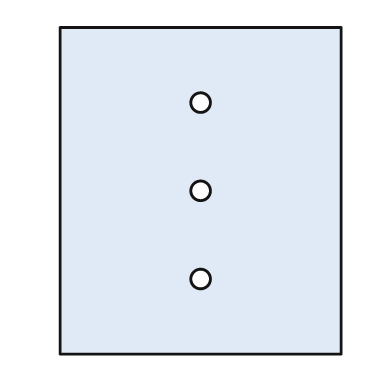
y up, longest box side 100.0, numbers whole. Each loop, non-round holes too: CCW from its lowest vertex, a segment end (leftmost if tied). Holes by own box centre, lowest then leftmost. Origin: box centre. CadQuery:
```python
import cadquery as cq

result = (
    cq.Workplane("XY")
    .moveTo(-43.0, -50.0)
    .lineTo(43.0, -50.0)
    .lineTo(43.0, 50.0)
    .lineTo(-43.0, 50.0)
    .close()
    .moveTo(0.0, -27.0)
    .circle(3.0)
    .moveTo(0.0, 0.0)
    .circle(3.0)
    .moveTo(0.0, 27.0)
    .circle(3.0)
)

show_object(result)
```